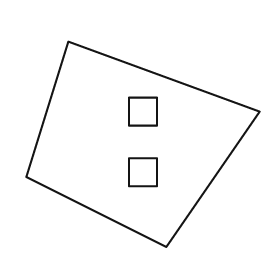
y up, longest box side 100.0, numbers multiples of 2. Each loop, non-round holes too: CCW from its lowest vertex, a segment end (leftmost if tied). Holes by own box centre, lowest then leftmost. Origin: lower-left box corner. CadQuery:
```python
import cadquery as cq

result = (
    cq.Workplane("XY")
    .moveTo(60.0, 0.0)
    .lineTo(100.0, 58.0)
    .lineTo(18.0, 88.0)
    .lineTo(0.0, 30.0)
    .close()
    .moveTo(44.0, 26.0)
    .lineTo(56.0, 26.0)
    .lineTo(56.0, 38.0)
    .lineTo(44.0, 38.0)
    .close()
    .moveTo(44.0, 52.0)
    .lineTo(56.0, 52.0)
    .lineTo(56.0, 64.0)
    .lineTo(44.0, 64.0)
    .close()
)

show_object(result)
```